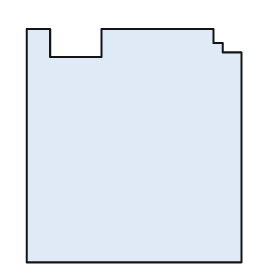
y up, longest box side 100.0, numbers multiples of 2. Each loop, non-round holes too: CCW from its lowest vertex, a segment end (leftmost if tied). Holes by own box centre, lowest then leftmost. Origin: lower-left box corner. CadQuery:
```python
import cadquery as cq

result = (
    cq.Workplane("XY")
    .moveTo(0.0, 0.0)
    .lineTo(92.0, 0.0)
    .lineTo(92.0, 90.0)
    .lineTo(84.0, 90.0)
    .lineTo(84.0, 94.0)
    .lineTo(80.0, 94.0)
    .lineTo(80.0, 100.0)
    .lineTo(32.0, 100.0)
    .lineTo(32.0, 88.0)
    .lineTo(10.0, 88.0)
    .lineTo(10.0, 100.0)
    .lineTo(0.0, 100.0)
    .close()
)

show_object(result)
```